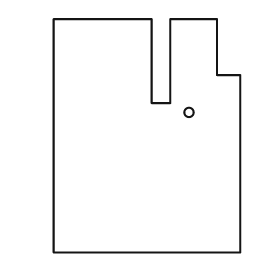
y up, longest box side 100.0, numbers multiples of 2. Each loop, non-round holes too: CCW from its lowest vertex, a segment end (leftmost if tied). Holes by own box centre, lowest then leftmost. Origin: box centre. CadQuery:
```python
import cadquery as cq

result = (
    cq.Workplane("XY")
    .moveTo(-40.0, -50.0)
    .lineTo(40.0, -50.0)
    .lineTo(40.0, 26.0)
    .lineTo(30.0, 26.0)
    .lineTo(30.0, 50.0)
    .lineTo(10.0, 50.0)
    .lineTo(10.0, 14.0)
    .lineTo(2.0, 14.0)
    .lineTo(2.0, 50.0)
    .lineTo(-40.0, 50.0)
    .close()
    .moveTo(18.0, 10.0)
    .circle(2.0)
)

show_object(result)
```